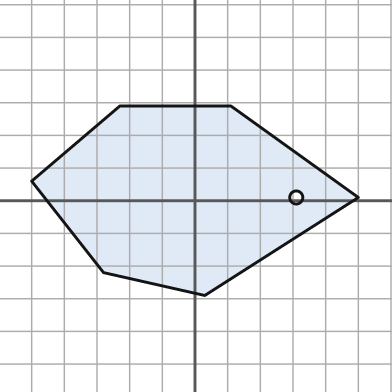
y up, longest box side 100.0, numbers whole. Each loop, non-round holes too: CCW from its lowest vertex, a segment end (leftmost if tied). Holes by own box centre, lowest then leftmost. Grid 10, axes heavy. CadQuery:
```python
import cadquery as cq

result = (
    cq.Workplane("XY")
    .moveTo(3.0, -29.0)
    .lineTo(50.0, 1.0)
    .lineTo(11.0, 29.0)
    .lineTo(-23.0, 29.0)
    .lineTo(-50.0, 6.0)
    .lineTo(-28.0, -22.0)
    .close()
    .moveTo(31.0, 1.0)
    .circle(2.0)
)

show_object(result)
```